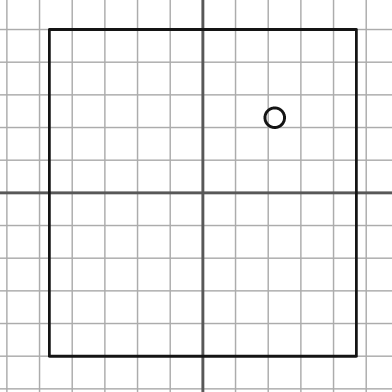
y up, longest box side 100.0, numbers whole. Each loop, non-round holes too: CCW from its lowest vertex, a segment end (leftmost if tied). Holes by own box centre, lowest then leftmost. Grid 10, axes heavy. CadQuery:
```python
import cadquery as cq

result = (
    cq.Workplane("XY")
    .moveTo(-47.0, -50.0)
    .lineTo(47.0, -50.0)
    .lineTo(47.0, 50.0)
    .lineTo(-47.0, 50.0)
    .close()
    .moveTo(22.0, 23.0)
    .circle(3.0)
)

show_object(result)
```